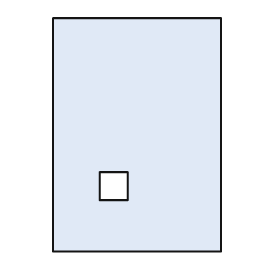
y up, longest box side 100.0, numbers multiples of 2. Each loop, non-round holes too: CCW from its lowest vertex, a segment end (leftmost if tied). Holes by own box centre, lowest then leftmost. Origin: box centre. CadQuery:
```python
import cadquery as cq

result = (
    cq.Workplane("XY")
    .moveTo(-36.0, -50.0)
    .lineTo(36.0, -50.0)
    .lineTo(36.0, 50.0)
    .lineTo(-36.0, 50.0)
    .close()
    .moveTo(-16.0, -28.0)
    .lineTo(-4.0, -28.0)
    .lineTo(-4.0, -16.0)
    .lineTo(-16.0, -16.0)
    .close()
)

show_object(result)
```